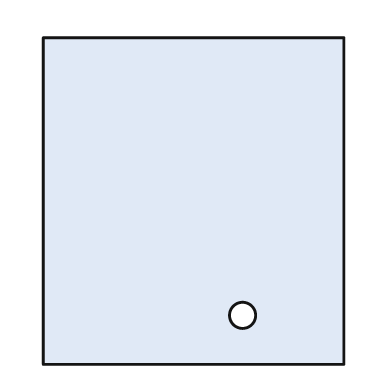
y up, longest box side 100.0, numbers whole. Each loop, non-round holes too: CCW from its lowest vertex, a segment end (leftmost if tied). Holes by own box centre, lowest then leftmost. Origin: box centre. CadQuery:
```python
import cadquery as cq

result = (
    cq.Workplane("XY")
    .moveTo(-46.0, -50.0)
    .lineTo(46.0, -50.0)
    .lineTo(46.0, 50.0)
    .lineTo(-46.0, 50.0)
    .close()
    .moveTo(15.0, -35.0)
    .circle(4.0)
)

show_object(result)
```